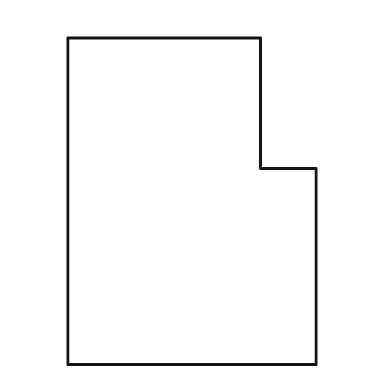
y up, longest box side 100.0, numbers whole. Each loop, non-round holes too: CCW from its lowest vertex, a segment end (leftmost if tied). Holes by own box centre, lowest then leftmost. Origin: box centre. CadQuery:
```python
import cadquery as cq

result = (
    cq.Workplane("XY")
    .moveTo(-38.0, -50.0)
    .lineTo(38.0, -50.0)
    .lineTo(38.0, 10.0)
    .lineTo(21.0, 10.0)
    .lineTo(21.0, 50.0)
    .lineTo(-38.0, 50.0)
    .close()
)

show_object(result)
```